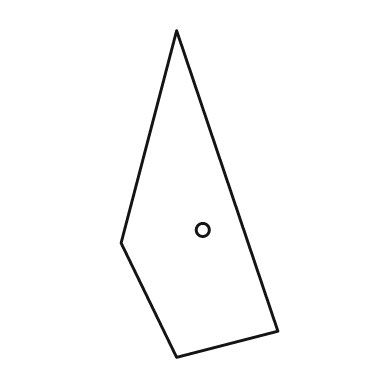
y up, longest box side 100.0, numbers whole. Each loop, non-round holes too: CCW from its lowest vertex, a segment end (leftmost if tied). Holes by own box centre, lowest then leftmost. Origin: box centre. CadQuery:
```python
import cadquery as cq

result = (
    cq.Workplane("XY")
    .moveTo(-7.0, -50.0)
    .lineTo(24.0, -42.0)
    .lineTo(-7.0, 50.0)
    .lineTo(-24.0, -15.0)
    .close()
    .moveTo(1.0, -11.0)
    .circle(2.0)
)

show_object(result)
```